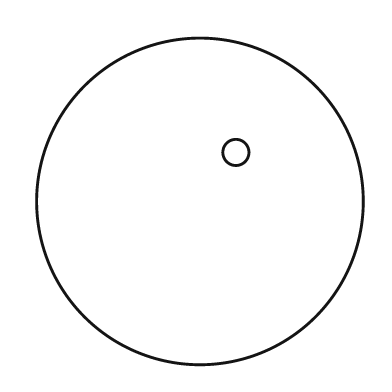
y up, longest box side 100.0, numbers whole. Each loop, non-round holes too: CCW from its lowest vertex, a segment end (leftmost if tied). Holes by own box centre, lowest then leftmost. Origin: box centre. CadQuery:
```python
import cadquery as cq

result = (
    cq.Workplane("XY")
    .moveTo(0.0, 0.0)
    .circle(50.0)
    .moveTo(11.0, 15.0)
    .circle(4.0)
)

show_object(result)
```